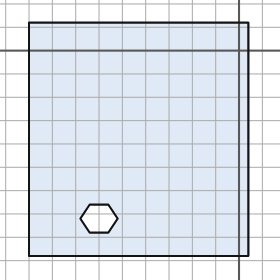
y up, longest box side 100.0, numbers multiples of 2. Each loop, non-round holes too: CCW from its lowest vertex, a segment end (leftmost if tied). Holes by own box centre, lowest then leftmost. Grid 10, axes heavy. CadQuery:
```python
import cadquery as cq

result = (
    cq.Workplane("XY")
    .moveTo(-90.0, -88.0)
    .lineTo(4.0, -88.0)
    .lineTo(4.0, 12.0)
    .lineTo(-90.0, 12.0)
    .close()
    .moveTo(-64.0, -78.0)
    .lineTo(-56.0, -78.0)
    .lineTo(-52.0, -72.0)
    .lineTo(-56.0, -66.0)
    .lineTo(-64.0, -66.0)
    .lineTo(-68.0, -72.0)
    .close()
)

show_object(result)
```